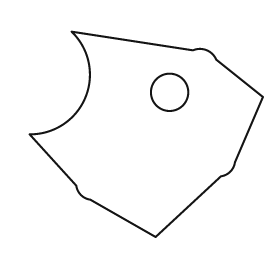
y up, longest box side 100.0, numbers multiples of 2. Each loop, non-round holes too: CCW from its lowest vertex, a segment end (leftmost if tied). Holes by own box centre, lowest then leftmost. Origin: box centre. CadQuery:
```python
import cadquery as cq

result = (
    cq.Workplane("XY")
    .moveTo(4.0, -44.0)
    .lineTo(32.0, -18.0)
    .threePointArc((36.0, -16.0), (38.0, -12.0))
    .lineTo(50.0, 16.0)
    .lineTo(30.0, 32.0)
    .threePointArc((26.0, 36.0), (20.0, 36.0))
    .lineTo(-32.0, 44.0)
    .threePointArc((-26.0, 16.0), (-50.0, 0.0))
    .lineTo(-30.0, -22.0)
    .threePointArc((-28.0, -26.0), (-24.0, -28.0))
    .close()
    .moveTo(10.0, 18.0)
    .circle(8.0)
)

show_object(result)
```